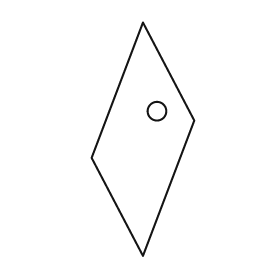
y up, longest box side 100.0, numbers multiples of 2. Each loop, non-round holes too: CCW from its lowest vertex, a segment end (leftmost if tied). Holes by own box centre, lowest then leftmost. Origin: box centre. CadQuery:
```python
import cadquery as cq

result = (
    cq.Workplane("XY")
    .moveTo(0.0, -50.0)
    .lineTo(22.0, 8.0)
    .lineTo(0.0, 50.0)
    .lineTo(-22.0, -8.0)
    .close()
    .moveTo(6.0, 12.0)
    .circle(4.0)
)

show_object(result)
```